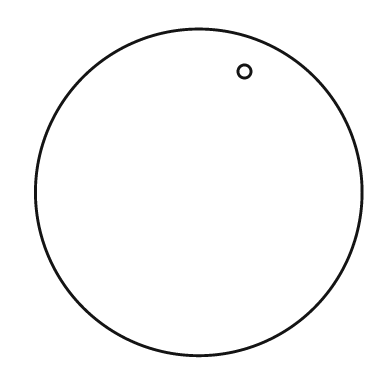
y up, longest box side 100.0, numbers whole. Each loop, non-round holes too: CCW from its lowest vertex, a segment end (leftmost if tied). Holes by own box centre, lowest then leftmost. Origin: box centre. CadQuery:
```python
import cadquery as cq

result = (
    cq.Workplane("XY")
    .moveTo(0.0, 0.0)
    .circle(50.0)
    .moveTo(14.0, 37.0)
    .circle(2.0)
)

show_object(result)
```